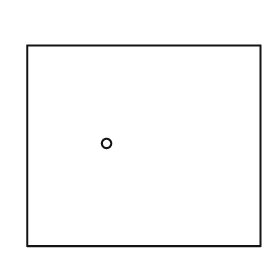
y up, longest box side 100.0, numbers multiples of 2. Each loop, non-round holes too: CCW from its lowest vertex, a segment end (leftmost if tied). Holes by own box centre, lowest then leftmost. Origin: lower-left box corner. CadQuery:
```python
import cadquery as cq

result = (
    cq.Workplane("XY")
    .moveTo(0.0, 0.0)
    .lineTo(100.0, 0.0)
    .lineTo(100.0, 86.0)
    .lineTo(0.0, 86.0)
    .close()
    .moveTo(34.0, 44.0)
    .circle(2.0)
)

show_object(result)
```